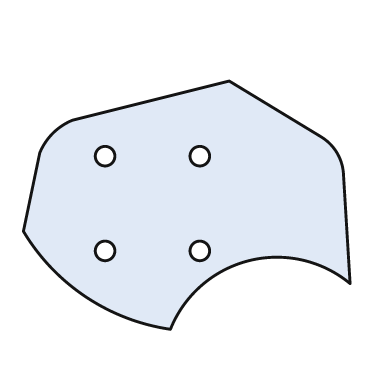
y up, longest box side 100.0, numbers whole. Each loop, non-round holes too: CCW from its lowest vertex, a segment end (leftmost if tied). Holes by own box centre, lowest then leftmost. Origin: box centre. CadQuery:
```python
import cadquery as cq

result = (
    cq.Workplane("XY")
    .moveTo(-5.0, -38.0)
    .threePointArc((19.0, -17.0), (50.0, -24.0))
    .lineTo(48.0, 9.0)
    .threePointArc((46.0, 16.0), (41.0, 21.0))
    .lineTo(13.0, 38.0)
    .lineTo(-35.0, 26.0)
    .threePointArc((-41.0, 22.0), (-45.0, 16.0))
    .lineTo(-50.0, -8.0)
    .threePointArc((-31.0, -28.0), (-5.0, -38.0))
    .close()
    .moveTo(-25.0, -14.0)
    .circle(3.0)
    .moveTo(4.0, -14.0)
    .circle(3.0)
    .moveTo(-25.0, 15.0)
    .circle(3.0)
    .moveTo(4.0, 15.0)
    .circle(3.0)
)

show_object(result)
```